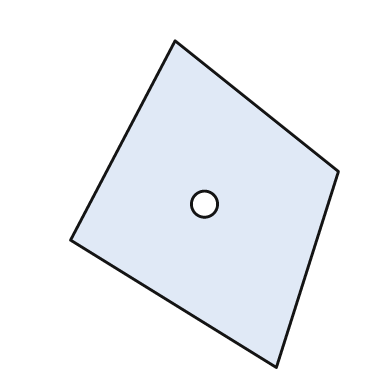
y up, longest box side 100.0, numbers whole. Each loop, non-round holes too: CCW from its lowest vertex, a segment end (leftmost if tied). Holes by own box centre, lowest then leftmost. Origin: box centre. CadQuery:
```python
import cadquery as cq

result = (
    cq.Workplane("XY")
    .moveTo(22.0, -50.0)
    .lineTo(41.0, 10.0)
    .lineTo(-9.0, 50.0)
    .lineTo(-41.0, -11.0)
    .close()
    .moveTo(0.0, 0.0)
    .circle(4.0)
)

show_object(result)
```